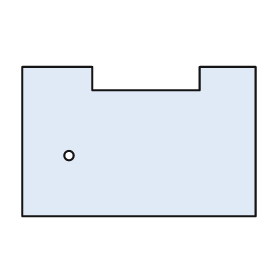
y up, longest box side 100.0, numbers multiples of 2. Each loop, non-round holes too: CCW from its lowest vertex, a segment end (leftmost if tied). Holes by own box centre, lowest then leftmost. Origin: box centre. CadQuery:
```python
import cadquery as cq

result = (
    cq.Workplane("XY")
    .moveTo(-50.0, -32.0)
    .lineTo(50.0, -32.0)
    .lineTo(50.0, 32.0)
    .lineTo(26.0, 32.0)
    .lineTo(26.0, 22.0)
    .lineTo(-20.0, 22.0)
    .lineTo(-20.0, 32.0)
    .lineTo(-50.0, 32.0)
    .close()
    .moveTo(-30.0, -6.0)
    .circle(2.0)
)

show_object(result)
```